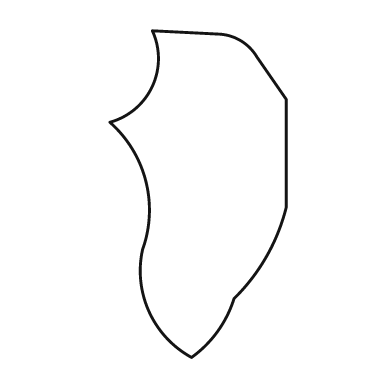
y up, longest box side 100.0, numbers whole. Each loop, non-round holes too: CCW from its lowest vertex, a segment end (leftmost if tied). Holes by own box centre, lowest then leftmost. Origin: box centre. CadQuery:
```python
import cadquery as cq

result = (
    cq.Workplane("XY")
    .moveTo(-2.0, -50.0)
    .threePointArc((6.0, -42.0), (11.0, -32.0))
    .threePointArc((21.0, -19.0), (27.0, -4.0))
    .lineTo(27.0, 29.0)
    .lineTo(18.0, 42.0)
    .threePointArc((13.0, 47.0), (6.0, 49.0))
    .lineTo(-14.0, 50.0)
    .threePointArc((-14.0, 33.0), (-27.0, 22.0))
    .threePointArc((-16.0, 4.0), (-17.0, -17.0))
    .threePointArc((-15.0, -36.0), (-2.0, -50.0))
    .close()
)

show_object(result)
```